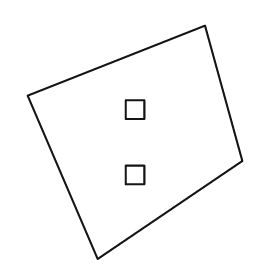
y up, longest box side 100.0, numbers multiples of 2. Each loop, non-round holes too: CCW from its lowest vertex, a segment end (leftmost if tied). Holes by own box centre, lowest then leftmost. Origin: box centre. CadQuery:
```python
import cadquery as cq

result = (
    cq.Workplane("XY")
    .moveTo(-16.0, -50.0)
    .lineTo(46.0, -8.0)
    .lineTo(30.0, 50.0)
    .lineTo(-46.0, 20.0)
    .close()
    .moveTo(-4.0, -18.0)
    .lineTo(4.0, -18.0)
    .lineTo(4.0, -10.0)
    .lineTo(-4.0, -10.0)
    .close()
    .moveTo(-4.0, 10.0)
    .lineTo(4.0, 10.0)
    .lineTo(4.0, 18.0)
    .lineTo(-4.0, 18.0)
    .close()
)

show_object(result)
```